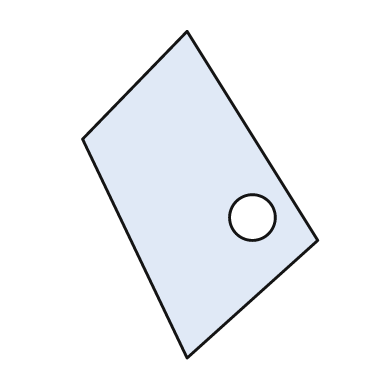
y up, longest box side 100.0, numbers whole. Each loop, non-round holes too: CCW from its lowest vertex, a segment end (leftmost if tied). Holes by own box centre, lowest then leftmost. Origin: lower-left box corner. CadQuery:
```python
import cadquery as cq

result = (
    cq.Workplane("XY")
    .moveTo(32.0, 0.0)
    .lineTo(72.0, 36.0)
    .lineTo(32.0, 100.0)
    .lineTo(0.0, 67.0)
    .close()
    .moveTo(52.0, 43.0)
    .circle(7.0)
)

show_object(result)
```